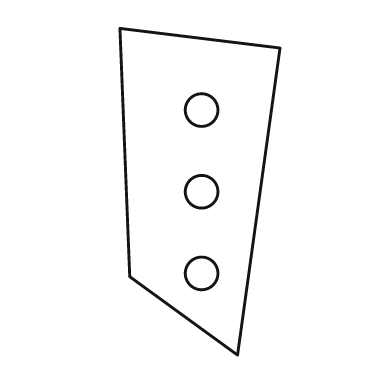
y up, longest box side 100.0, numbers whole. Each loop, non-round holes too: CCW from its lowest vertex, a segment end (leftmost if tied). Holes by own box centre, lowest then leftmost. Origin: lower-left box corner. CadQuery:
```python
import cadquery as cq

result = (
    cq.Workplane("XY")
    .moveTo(36.0, 0.0)
    .lineTo(49.0, 94.0)
    .lineTo(0.0, 100.0)
    .lineTo(3.0, 24.0)
    .close()
    .moveTo(25.0, 25.0)
    .circle(5.0)
    .moveTo(25.0, 50.0)
    .circle(5.0)
    .moveTo(25.0, 75.0)
    .circle(5.0)
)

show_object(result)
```